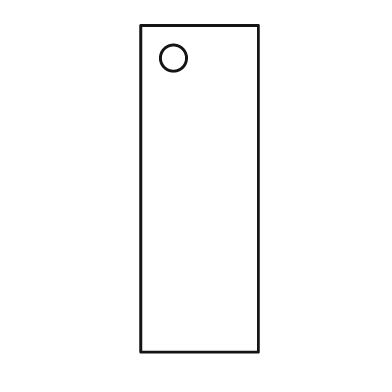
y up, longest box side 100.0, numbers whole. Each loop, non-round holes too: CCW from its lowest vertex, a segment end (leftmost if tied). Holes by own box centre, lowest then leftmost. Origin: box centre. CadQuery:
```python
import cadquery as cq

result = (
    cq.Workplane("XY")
    .moveTo(-18.0, -50.0)
    .lineTo(18.0, -50.0)
    .lineTo(18.0, 50.0)
    .lineTo(-18.0, 50.0)
    .close()
    .moveTo(-8.0, 40.0)
    .circle(4.0)
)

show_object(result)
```